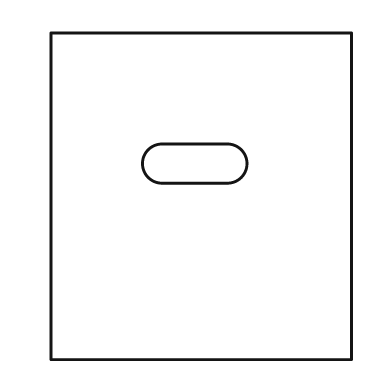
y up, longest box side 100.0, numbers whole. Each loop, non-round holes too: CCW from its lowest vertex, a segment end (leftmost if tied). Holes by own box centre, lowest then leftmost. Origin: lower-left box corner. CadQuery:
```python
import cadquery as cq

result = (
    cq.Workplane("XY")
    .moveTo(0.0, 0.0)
    .lineTo(92.0, 0.0)
    .lineTo(92.0, 100.0)
    .lineTo(0.0, 100.0)
    .close()
    .moveTo(34.0, 54.0)
    .lineTo(54.0, 54.0)
    .threePointArc((60.0, 60.0), (54.0, 66.0))
    .lineTo(34.0, 66.0)
    .threePointArc((28.0, 60.0), (34.0, 54.0))
    .close()
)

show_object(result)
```